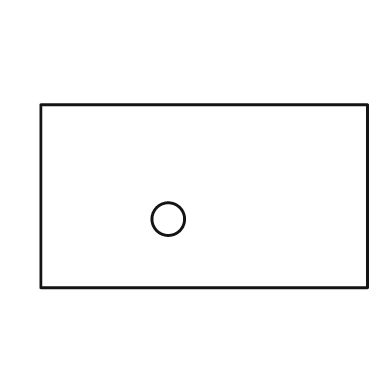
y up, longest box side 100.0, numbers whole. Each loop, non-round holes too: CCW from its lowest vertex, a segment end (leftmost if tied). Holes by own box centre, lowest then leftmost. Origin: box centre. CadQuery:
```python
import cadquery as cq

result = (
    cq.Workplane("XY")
    .moveTo(-50.0, -28.0)
    .lineTo(50.0, -28.0)
    .lineTo(50.0, 28.0)
    .lineTo(-50.0, 28.0)
    .close()
    .moveTo(-11.0, -7.0)
    .circle(5.0)
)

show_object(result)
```